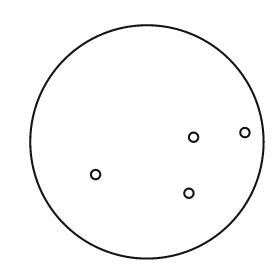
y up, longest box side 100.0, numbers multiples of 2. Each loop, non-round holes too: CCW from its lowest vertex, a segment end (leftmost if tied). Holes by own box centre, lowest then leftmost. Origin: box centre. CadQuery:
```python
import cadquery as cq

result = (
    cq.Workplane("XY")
    .moveTo(0.0, 0.0)
    .circle(50.0)
    .moveTo(18.0, -22.0)
    .circle(2.0)
    .moveTo(-22.0, -14.0)
    .circle(2.0)
    .moveTo(20.0, 2.0)
    .circle(2.0)
    .moveTo(42.0, 4.0)
    .circle(2.0)
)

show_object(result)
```